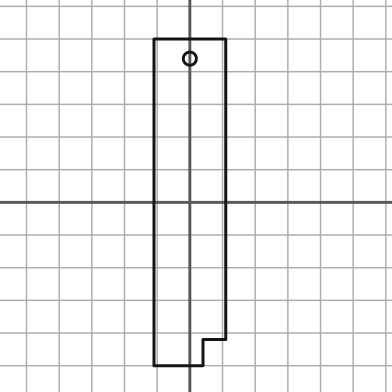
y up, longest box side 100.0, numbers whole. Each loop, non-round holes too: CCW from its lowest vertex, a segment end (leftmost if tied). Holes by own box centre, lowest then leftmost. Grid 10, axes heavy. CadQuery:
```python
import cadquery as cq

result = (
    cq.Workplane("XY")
    .moveTo(-11.0, -50.0)
    .lineTo(4.0, -50.0)
    .lineTo(4.0, -42.0)
    .lineTo(11.0, -42.0)
    .lineTo(11.0, 50.0)
    .lineTo(-11.0, 50.0)
    .close()
    .moveTo(0.0, 44.0)
    .circle(2.0)
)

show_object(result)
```